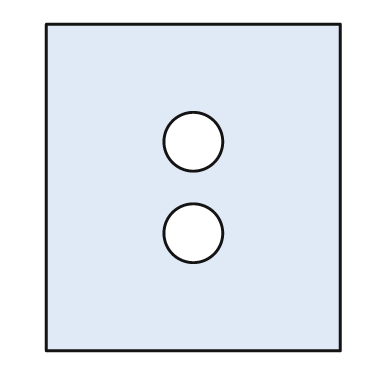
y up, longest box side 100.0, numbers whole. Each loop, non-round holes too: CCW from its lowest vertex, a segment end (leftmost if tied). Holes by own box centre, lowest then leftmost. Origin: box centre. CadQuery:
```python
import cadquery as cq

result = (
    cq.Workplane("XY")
    .moveTo(-45.0, -50.0)
    .lineTo(45.0, -50.0)
    .lineTo(45.0, 50.0)
    .lineTo(-45.0, 50.0)
    .close()
    .moveTo(0.0, -14.0)
    .circle(9.0)
    .moveTo(0.0, 14.0)
    .circle(9.0)
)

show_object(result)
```